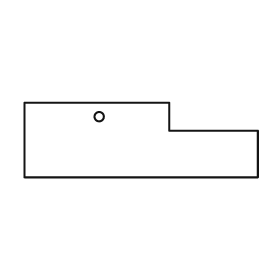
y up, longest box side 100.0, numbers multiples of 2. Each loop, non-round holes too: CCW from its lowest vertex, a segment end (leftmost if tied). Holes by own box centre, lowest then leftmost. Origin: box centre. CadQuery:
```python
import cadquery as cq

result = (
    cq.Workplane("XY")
    .moveTo(-50.0, -16.0)
    .lineTo(50.0, -16.0)
    .lineTo(50.0, 4.0)
    .lineTo(12.0, 4.0)
    .lineTo(12.0, 16.0)
    .lineTo(-50.0, 16.0)
    .close()
    .moveTo(-18.0, 10.0)
    .circle(2.0)
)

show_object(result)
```